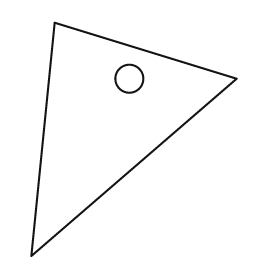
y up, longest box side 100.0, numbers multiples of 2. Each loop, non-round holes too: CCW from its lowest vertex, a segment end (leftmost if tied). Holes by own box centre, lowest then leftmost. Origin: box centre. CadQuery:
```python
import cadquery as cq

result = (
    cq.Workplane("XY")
    .moveTo(-44.0, -50.0)
    .lineTo(44.0, 26.0)
    .lineTo(-34.0, 50.0)
    .close()
    .moveTo(-2.0, 26.0)
    .circle(6.0)
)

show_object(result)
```